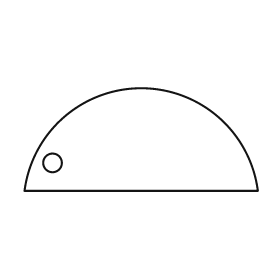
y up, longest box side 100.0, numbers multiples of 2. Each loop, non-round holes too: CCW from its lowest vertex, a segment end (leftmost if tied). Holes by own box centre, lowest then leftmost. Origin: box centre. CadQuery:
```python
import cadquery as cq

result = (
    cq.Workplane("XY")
    .moveTo(-50.0, -22.0)
    .lineTo(50.0, -22.0)
    .threePointArc((0.0, 22.0), (-50.0, -22.0))
    .close()
    .moveTo(-38.0, -10.0)
    .circle(4.0)
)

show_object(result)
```